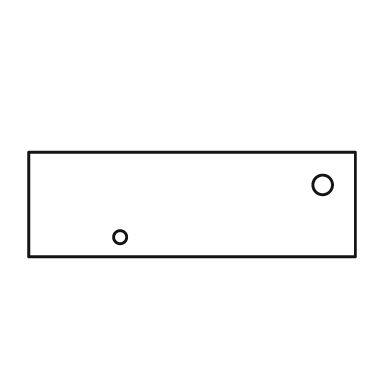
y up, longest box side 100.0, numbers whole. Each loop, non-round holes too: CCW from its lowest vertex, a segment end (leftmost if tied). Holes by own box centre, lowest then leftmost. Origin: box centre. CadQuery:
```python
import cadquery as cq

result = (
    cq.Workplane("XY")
    .moveTo(-50.0, -16.0)
    .lineTo(50.0, -16.0)
    .lineTo(50.0, 16.0)
    .lineTo(-50.0, 16.0)
    .close()
    .moveTo(-22.0, -10.0)
    .circle(2.0)
    .moveTo(40.0, 6.0)
    .circle(3.0)
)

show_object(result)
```